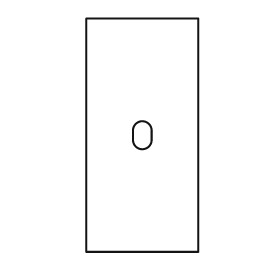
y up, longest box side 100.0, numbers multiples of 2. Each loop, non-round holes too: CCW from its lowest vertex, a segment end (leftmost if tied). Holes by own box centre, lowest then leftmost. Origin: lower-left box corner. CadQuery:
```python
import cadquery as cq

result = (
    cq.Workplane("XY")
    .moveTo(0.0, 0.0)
    .lineTo(48.0, 0.0)
    .lineTo(48.0, 100.0)
    .lineTo(0.0, 100.0)
    .close()
    .moveTo(20.0, 48.0)
    .threePointArc((24.0, 44.0), (28.0, 48.0))
    .lineTo(28.0, 52.0)
    .threePointArc((24.0, 56.0), (20.0, 52.0))
    .close()
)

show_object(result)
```